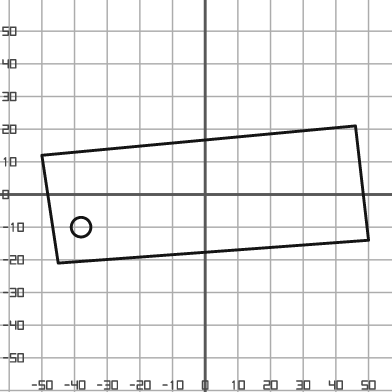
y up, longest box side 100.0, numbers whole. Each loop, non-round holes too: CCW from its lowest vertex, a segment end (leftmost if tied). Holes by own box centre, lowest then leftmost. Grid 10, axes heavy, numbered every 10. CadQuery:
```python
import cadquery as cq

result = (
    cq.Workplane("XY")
    .moveTo(-45.0, -21.0)
    .lineTo(50.0, -14.0)
    .lineTo(46.0, 21.0)
    .lineTo(-50.0, 12.0)
    .close()
    .moveTo(-38.0, -10.0)
    .circle(3.0)
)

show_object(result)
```